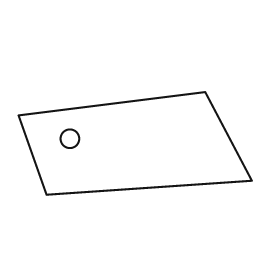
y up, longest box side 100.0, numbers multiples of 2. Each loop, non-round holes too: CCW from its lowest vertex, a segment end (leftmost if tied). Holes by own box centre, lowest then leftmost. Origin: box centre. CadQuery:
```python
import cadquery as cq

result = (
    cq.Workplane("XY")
    .moveTo(-38.0, -22.0)
    .lineTo(50.0, -16.0)
    .lineTo(30.0, 22.0)
    .lineTo(-50.0, 12.0)
    .close()
    .moveTo(-28.0, 2.0)
    .circle(4.0)
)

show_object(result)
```